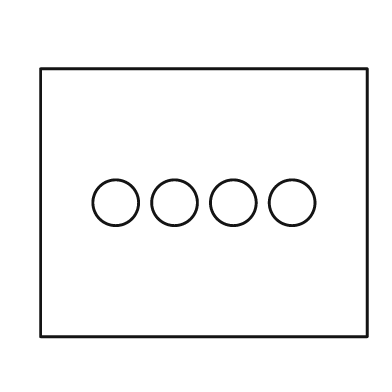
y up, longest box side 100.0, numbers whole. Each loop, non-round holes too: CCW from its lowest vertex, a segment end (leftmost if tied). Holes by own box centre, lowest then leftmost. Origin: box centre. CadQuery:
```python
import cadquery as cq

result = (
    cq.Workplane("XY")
    .moveTo(-50.0, -41.0)
    .lineTo(50.0, -41.0)
    .lineTo(50.0, 41.0)
    .lineTo(-50.0, 41.0)
    .close()
    .moveTo(-27.0, 0.0)
    .circle(7.0)
    .moveTo(-9.0, 0.0)
    .circle(7.0)
    .moveTo(9.0, 0.0)
    .circle(7.0)
    .moveTo(27.0, 0.0)
    .circle(7.0)
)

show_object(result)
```